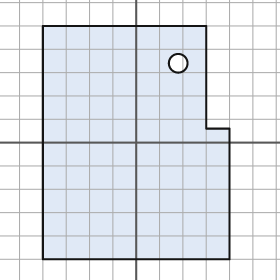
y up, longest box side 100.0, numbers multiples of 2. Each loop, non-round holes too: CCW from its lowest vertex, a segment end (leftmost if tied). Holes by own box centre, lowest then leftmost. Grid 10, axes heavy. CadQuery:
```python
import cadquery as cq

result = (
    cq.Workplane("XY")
    .moveTo(-40.0, -50.0)
    .lineTo(40.0, -50.0)
    .lineTo(40.0, 6.0)
    .lineTo(30.0, 6.0)
    .lineTo(30.0, 50.0)
    .lineTo(-40.0, 50.0)
    .close()
    .moveTo(18.0, 34.0)
    .circle(4.0)
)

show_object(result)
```